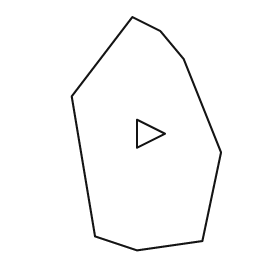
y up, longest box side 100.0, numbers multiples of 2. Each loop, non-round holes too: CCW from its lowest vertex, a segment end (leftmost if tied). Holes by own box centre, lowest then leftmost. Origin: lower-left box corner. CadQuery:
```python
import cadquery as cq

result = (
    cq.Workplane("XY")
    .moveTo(28.0, 0.0)
    .lineTo(56.0, 4.0)
    .lineTo(64.0, 42.0)
    .lineTo(48.0, 82.0)
    .lineTo(38.0, 94.0)
    .lineTo(26.0, 100.0)
    .lineTo(0.0, 66.0)
    .lineTo(10.0, 6.0)
    .close()
    .moveTo(28.0, 44.0)
    .lineTo(40.0, 50.0)
    .lineTo(28.0, 56.0)
    .close()
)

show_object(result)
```